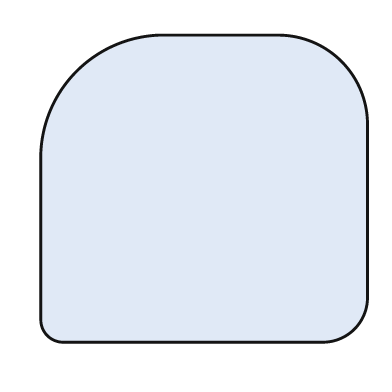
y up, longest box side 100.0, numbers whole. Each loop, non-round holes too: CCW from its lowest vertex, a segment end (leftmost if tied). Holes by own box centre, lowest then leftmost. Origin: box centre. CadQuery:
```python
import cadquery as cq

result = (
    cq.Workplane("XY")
    .moveTo(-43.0, -47.0)
    .lineTo(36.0, -47.0)
    .threePointArc((46.0, -43.0), (50.0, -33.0))
    .lineTo(50.0, 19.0)
    .threePointArc((42.0, 39.0), (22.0, 47.0))
    .lineTo(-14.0, 47.0)
    .threePointArc((-39.0, 36.0), (-50.0, 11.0))
    .lineTo(-50.0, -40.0)
    .threePointArc((-48.0, -45.0), (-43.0, -47.0))
    .close()
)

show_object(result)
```